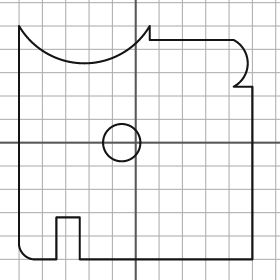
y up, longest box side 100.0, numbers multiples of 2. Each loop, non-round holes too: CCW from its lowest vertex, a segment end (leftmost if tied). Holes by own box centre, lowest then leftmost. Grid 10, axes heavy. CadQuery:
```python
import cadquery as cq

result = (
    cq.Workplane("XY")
    .moveTo(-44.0, -50.0)
    .lineTo(-34.0, -50.0)
    .lineTo(-34.0, -32.0)
    .lineTo(-24.0, -32.0)
    .lineTo(-24.0, -50.0)
    .lineTo(50.0, -50.0)
    .lineTo(50.0, 24.0)
    .lineTo(42.0, 24.0)
    .threePointArc((48.0, 34.0), (42.0, 44.0))
    .lineTo(6.0, 44.0)
    .lineTo(6.0, 50.0)
    .threePointArc((-22.0, 34.0), (-50.0, 50.0))
    .lineTo(-50.0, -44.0)
    .threePointArc((-48.0, -48.0), (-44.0, -50.0))
    .close()
    .moveTo(-6.0, 0.0)
    .circle(8.0)
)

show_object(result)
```